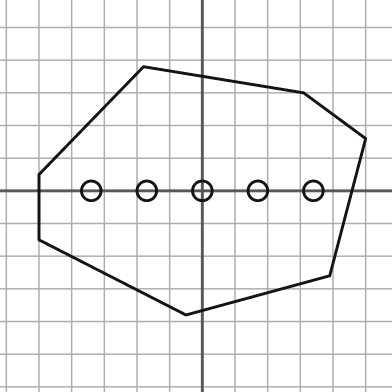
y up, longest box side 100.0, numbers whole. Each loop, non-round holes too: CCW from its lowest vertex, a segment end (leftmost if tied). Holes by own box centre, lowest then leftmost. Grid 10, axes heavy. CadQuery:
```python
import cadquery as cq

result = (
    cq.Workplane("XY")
    .moveTo(-5.0, -38.0)
    .lineTo(39.0, -26.0)
    .lineTo(50.0, 16.0)
    .lineTo(31.0, 30.0)
    .lineTo(-18.0, 38.0)
    .lineTo(-50.0, 5.0)
    .lineTo(-50.0, -15.0)
    .close()
    .moveTo(-34.0, 0.0)
    .circle(3.0)
    .moveTo(-17.0, 0.0)
    .circle(3.0)
    .moveTo(0.0, 0.0)
    .circle(3.0)
    .moveTo(17.0, 0.0)
    .circle(3.0)
    .moveTo(34.0, 0.0)
    .circle(3.0)
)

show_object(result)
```